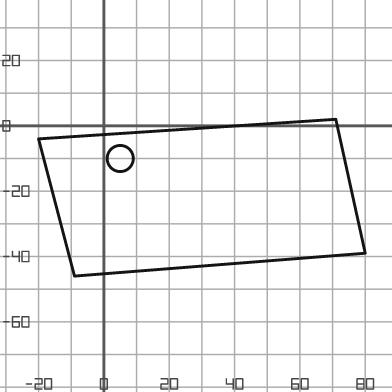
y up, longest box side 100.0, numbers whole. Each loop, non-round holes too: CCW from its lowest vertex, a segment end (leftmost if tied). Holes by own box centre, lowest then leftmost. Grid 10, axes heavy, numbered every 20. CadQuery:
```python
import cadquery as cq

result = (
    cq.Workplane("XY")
    .moveTo(-9.0, -46.0)
    .lineTo(80.0, -39.0)
    .lineTo(71.0, 2.0)
    .lineTo(-20.0, -4.0)
    .close()
    .moveTo(5.0, -10.0)
    .circle(4.0)
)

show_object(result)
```